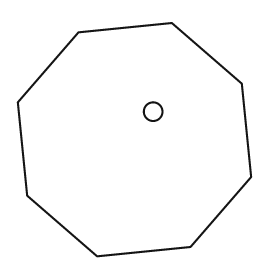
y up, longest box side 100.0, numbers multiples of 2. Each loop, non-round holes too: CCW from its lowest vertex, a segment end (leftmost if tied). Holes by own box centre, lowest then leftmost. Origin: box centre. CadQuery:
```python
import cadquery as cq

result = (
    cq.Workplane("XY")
    .moveTo(-16.0, -50.0)
    .lineTo(24.0, -46.0)
    .lineTo(50.0, -16.0)
    .lineTo(46.0, 24.0)
    .lineTo(16.0, 50.0)
    .lineTo(-24.0, 46.0)
    .lineTo(-50.0, 16.0)
    .lineTo(-46.0, -24.0)
    .close()
    .moveTo(8.0, 12.0)
    .circle(4.0)
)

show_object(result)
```